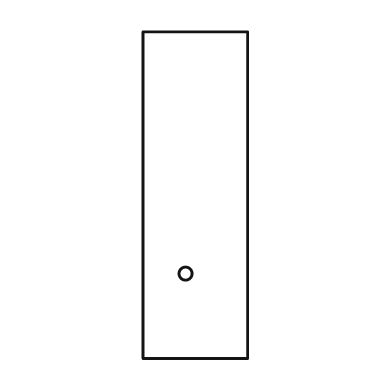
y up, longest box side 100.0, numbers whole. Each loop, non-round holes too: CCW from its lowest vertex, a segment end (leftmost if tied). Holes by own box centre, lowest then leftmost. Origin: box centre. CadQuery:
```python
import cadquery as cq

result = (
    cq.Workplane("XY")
    .moveTo(-16.0, -50.0)
    .lineTo(16.0, -50.0)
    .lineTo(16.0, 50.0)
    .lineTo(-16.0, 50.0)
    .close()
    .moveTo(-3.0, -24.0)
    .circle(2.0)
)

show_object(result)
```